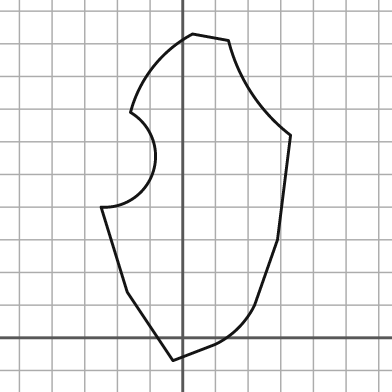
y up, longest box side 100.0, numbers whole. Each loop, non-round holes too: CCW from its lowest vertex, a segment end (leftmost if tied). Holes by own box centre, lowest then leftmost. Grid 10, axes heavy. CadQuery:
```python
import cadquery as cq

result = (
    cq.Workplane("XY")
    .moveTo(-3.0, -7.0)
    .lineTo(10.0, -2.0)
    .threePointArc((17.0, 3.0), (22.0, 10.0))
    .lineTo(29.0, 30.0)
    .lineTo(33.0, 62.0)
    .threePointArc((21.0, 75.0), (14.0, 91.0))
    .lineTo(3.0, 93.0)
    .threePointArc((-9.0, 83.0), (-16.0, 69.0))
    .threePointArc((-9.0, 51.0), (-25.0, 40.0))
    .lineTo(-17.0, 14.0)
    .close()
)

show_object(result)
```